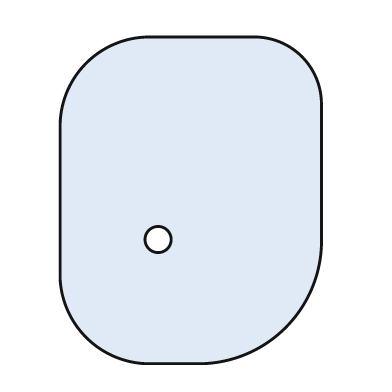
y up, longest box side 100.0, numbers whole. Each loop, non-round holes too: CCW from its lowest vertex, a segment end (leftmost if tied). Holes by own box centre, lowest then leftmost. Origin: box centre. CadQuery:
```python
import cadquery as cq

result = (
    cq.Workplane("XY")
    .moveTo(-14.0, -50.0)
    .lineTo(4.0, -50.0)
    .threePointArc((29.0, -39.0), (40.0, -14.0))
    .lineTo(40.0, 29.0)
    .threePointArc((34.0, 44.0), (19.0, 50.0))
    .lineTo(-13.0, 50.0)
    .threePointArc((-32.0, 42.0), (-40.0, 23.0))
    .lineTo(-40.0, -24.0)
    .threePointArc((-32.0, -42.0), (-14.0, -50.0))
    .close()
    .moveTo(-10.0, -12.0)
    .circle(4.0)
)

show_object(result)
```